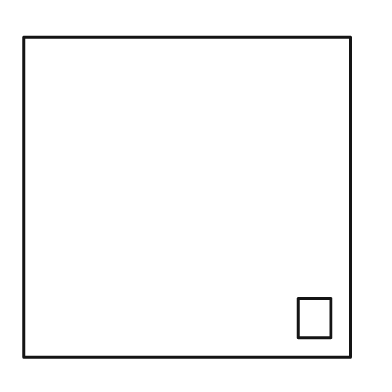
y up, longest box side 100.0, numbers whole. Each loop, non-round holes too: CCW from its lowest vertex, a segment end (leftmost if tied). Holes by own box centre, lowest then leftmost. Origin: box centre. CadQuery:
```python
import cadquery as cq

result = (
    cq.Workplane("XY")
    .moveTo(-50.0, -49.0)
    .lineTo(50.0, -49.0)
    .lineTo(50.0, 49.0)
    .lineTo(-50.0, 49.0)
    .close()
    .moveTo(34.0, -43.0)
    .lineTo(44.0, -43.0)
    .lineTo(44.0, -31.0)
    .lineTo(34.0, -31.0)
    .close()
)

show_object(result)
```